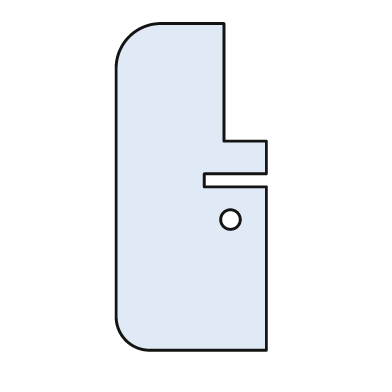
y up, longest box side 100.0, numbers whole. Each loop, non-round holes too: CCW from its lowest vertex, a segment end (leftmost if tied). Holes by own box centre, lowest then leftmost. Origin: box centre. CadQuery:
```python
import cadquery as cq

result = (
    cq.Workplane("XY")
    .moveTo(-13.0, -50.0)
    .lineTo(23.0, -50.0)
    .lineTo(23.0, 0.0)
    .lineTo(4.0, 0.0)
    .lineTo(4.0, 4.0)
    .lineTo(23.0, 4.0)
    .lineTo(23.0, 14.0)
    .lineTo(10.0, 14.0)
    .lineTo(10.0, 50.0)
    .lineTo(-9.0, 50.0)
    .threePointArc((-19.0, 46.0), (-23.0, 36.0))
    .lineTo(-23.0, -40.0)
    .threePointArc((-20.0, -47.0), (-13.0, -50.0))
    .close()
    .moveTo(12.0, -10.0)
    .circle(3.0)
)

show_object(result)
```